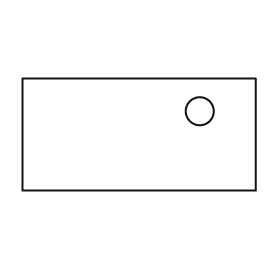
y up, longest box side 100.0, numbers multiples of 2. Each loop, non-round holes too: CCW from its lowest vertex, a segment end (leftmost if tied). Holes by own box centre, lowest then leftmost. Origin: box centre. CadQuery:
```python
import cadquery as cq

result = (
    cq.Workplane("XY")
    .moveTo(-50.0, -24.0)
    .lineTo(50.0, -24.0)
    .lineTo(50.0, 24.0)
    .lineTo(-50.0, 24.0)
    .close()
    .moveTo(26.0, 10.0)
    .circle(6.0)
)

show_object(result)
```